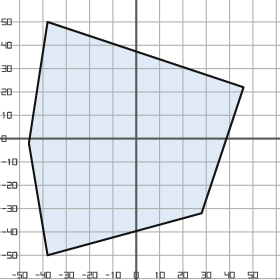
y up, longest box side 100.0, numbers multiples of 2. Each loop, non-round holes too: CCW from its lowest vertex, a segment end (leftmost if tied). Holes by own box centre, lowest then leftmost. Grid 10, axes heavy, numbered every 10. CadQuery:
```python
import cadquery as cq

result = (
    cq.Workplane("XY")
    .moveTo(-38.0, -50.0)
    .lineTo(28.0, -32.0)
    .lineTo(46.0, 22.0)
    .lineTo(-38.0, 50.0)
    .lineTo(-46.0, -2.0)
    .close()
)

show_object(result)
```